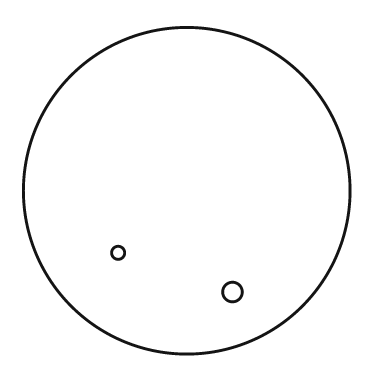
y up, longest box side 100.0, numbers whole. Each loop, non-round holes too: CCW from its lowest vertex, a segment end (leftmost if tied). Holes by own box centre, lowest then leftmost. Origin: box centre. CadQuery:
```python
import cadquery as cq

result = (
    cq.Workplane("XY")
    .moveTo(0.0, 0.0)
    .circle(50.0)
    .moveTo(14.0, -31.0)
    .circle(3.0)
    .moveTo(-21.0, -19.0)
    .circle(2.0)
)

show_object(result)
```